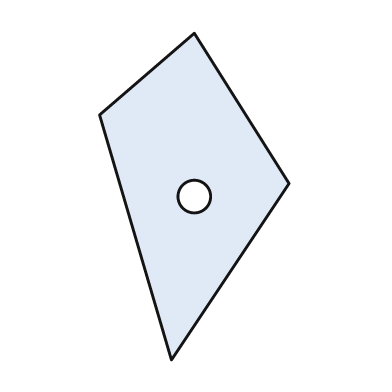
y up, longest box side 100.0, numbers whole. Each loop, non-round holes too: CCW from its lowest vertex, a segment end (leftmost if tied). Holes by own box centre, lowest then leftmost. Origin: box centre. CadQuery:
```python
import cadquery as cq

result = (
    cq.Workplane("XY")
    .moveTo(-7.0, -50.0)
    .lineTo(29.0, 4.0)
    .lineTo(0.0, 50.0)
    .lineTo(-29.0, 25.0)
    .close()
    .moveTo(0.0, 0.0)
    .circle(5.0)
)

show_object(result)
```